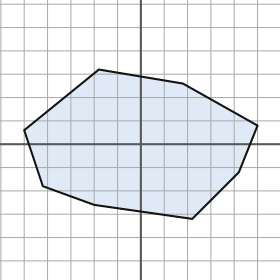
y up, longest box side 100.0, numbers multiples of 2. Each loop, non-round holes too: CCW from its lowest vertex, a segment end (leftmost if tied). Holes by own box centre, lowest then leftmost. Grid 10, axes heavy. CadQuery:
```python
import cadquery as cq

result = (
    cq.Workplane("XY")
    .moveTo(22.0, -32.0)
    .lineTo(42.0, -12.0)
    .lineTo(50.0, 8.0)
    .lineTo(18.0, 26.0)
    .lineTo(-18.0, 32.0)
    .lineTo(-50.0, 6.0)
    .lineTo(-42.0, -18.0)
    .lineTo(-20.0, -26.0)
    .close()
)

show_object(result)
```